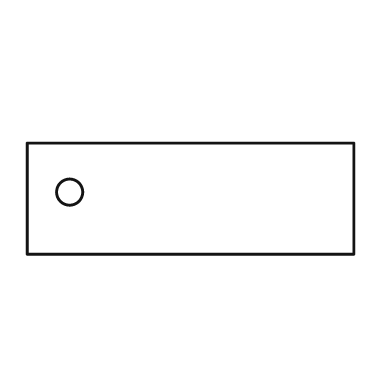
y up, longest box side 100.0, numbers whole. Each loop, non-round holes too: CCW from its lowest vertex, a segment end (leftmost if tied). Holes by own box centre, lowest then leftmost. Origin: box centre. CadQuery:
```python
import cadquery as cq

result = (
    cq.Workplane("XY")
    .moveTo(-50.0, -17.0)
    .lineTo(50.0, -17.0)
    .lineTo(50.0, 17.0)
    .lineTo(-50.0, 17.0)
    .close()
    .moveTo(-37.0, 2.0)
    .circle(4.0)
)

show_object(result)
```